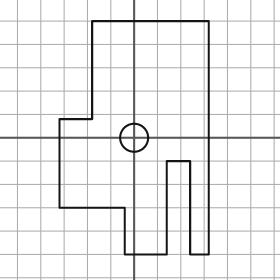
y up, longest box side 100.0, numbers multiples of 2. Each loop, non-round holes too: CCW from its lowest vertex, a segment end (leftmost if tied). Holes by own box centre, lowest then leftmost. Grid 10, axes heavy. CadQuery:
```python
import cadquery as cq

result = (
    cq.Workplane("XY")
    .moveTo(-4.0, -50.0)
    .lineTo(14.0, -50.0)
    .lineTo(14.0, -10.0)
    .lineTo(24.0, -10.0)
    .lineTo(24.0, -50.0)
    .lineTo(32.0, -50.0)
    .lineTo(32.0, 50.0)
    .lineTo(-18.0, 50.0)
    .lineTo(-18.0, 8.0)
    .lineTo(-32.0, 8.0)
    .lineTo(-32.0, -30.0)
    .lineTo(-4.0, -30.0)
    .close()
    .moveTo(0.0, 0.0)
    .circle(6.0)
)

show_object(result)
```